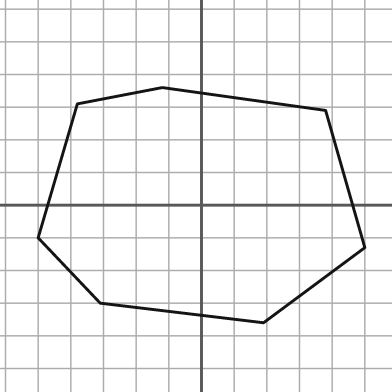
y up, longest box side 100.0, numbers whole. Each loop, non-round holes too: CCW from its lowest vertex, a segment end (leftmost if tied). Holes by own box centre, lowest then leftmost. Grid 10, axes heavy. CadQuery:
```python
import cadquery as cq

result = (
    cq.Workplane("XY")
    .moveTo(19.0, -36.0)
    .lineTo(50.0, -13.0)
    .lineTo(38.0, 29.0)
    .lineTo(-12.0, 36.0)
    .lineTo(-38.0, 31.0)
    .lineTo(-50.0, -10.0)
    .lineTo(-31.0, -30.0)
    .close()
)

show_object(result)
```